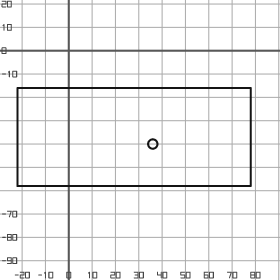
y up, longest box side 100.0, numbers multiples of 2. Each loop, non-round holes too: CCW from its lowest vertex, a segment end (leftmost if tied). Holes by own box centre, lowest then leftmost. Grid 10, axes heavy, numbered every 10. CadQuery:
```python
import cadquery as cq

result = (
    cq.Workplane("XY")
    .moveTo(-22.0, -58.0)
    .lineTo(78.0, -58.0)
    .lineTo(78.0, -16.0)
    .lineTo(-22.0, -16.0)
    .close()
    .moveTo(36.0, -40.0)
    .circle(2.0)
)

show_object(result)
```